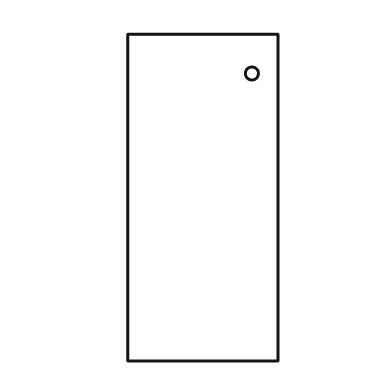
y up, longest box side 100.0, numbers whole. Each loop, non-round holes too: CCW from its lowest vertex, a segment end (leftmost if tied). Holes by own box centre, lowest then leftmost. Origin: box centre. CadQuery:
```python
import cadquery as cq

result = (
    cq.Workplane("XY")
    .moveTo(-23.0, -50.0)
    .lineTo(23.0, -50.0)
    .lineTo(23.0, 50.0)
    .lineTo(-23.0, 50.0)
    .close()
    .moveTo(15.0, 38.0)
    .circle(2.0)
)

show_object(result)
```